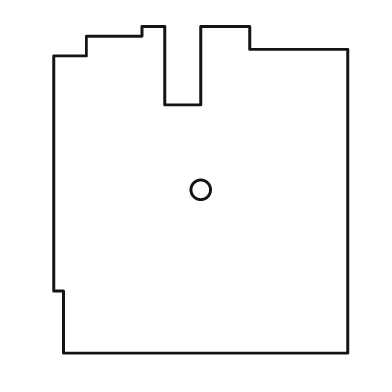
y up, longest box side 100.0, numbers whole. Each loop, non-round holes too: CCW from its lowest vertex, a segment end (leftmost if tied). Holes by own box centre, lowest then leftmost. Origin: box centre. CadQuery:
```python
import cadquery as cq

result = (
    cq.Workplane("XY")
    .moveTo(-42.0, -50.0)
    .lineTo(45.0, -50.0)
    .lineTo(45.0, 43.0)
    .lineTo(15.0, 43.0)
    .lineTo(15.0, 50.0)
    .lineTo(0.0, 50.0)
    .lineTo(0.0, 26.0)
    .lineTo(-11.0, 26.0)
    .lineTo(-11.0, 50.0)
    .lineTo(-18.0, 50.0)
    .lineTo(-18.0, 47.0)
    .lineTo(-35.0, 47.0)
    .lineTo(-35.0, 41.0)
    .lineTo(-45.0, 41.0)
    .lineTo(-45.0, -31.0)
    .lineTo(-42.0, -31.0)
    .close()
    .moveTo(0.0, 0.0)
    .circle(3.0)
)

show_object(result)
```